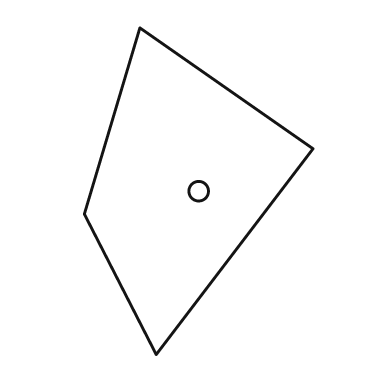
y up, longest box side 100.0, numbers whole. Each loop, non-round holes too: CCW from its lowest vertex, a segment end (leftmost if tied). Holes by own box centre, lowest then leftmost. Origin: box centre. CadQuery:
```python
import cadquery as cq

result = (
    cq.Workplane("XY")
    .moveTo(-13.0, -50.0)
    .lineTo(35.0, 13.0)
    .lineTo(-18.0, 50.0)
    .lineTo(-35.0, -7.0)
    .close()
    .moveTo(0.0, 0.0)
    .circle(3.0)
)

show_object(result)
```